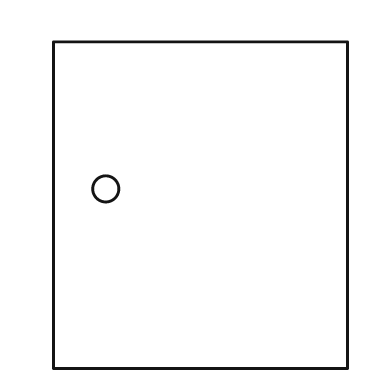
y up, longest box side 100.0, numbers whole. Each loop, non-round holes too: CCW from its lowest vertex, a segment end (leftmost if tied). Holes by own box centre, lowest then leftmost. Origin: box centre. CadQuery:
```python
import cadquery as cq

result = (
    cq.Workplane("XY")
    .moveTo(-45.0, -50.0)
    .lineTo(45.0, -50.0)
    .lineTo(45.0, 50.0)
    .lineTo(-45.0, 50.0)
    .close()
    .moveTo(-29.0, 5.0)
    .circle(4.0)
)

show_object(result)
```